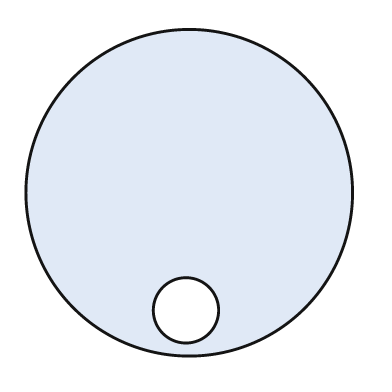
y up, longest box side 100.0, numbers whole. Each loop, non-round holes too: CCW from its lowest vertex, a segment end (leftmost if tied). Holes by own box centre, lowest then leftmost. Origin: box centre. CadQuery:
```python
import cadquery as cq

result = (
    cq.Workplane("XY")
    .moveTo(0.0, 0.0)
    .circle(50.0)
    .moveTo(-1.0, -36.0)
    .circle(10.0)
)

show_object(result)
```